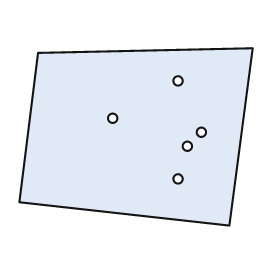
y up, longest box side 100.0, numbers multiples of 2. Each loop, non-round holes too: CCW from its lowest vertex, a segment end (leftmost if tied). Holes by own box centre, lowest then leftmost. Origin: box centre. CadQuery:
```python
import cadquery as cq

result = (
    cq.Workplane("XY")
    .moveTo(40.0, -38.0)
    .lineTo(50.0, 38.0)
    .lineTo(-42.0, 36.0)
    .lineTo(-50.0, -28.0)
    .close()
    .moveTo(18.0, -18.0)
    .circle(2.0)
    .moveTo(22.0, -4.0)
    .circle(2.0)
    .moveTo(28.0, 2.0)
    .circle(2.0)
    .moveTo(-10.0, 8.0)
    .circle(2.0)
    .moveTo(18.0, 24.0)
    .circle(2.0)
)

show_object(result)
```